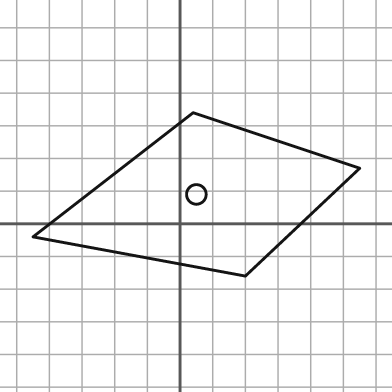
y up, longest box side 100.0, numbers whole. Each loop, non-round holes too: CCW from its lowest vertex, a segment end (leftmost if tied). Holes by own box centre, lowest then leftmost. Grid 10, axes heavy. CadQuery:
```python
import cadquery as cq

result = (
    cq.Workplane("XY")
    .moveTo(20.0, -16.0)
    .lineTo(55.0, 17.0)
    .lineTo(4.0, 34.0)
    .lineTo(-45.0, -4.0)
    .close()
    .moveTo(5.0, 9.0)
    .circle(3.0)
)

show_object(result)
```